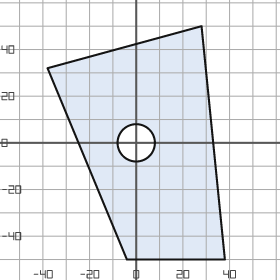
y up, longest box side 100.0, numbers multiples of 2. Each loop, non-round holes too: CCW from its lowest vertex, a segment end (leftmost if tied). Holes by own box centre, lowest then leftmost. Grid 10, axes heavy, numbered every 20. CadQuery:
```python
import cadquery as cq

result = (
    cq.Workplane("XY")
    .moveTo(-4.0, -50.0)
    .lineTo(38.0, -50.0)
    .lineTo(28.0, 50.0)
    .lineTo(-38.0, 32.0)
    .close()
    .moveTo(0.0, 0.0)
    .circle(8.0)
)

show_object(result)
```